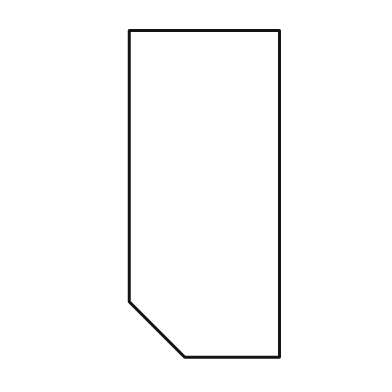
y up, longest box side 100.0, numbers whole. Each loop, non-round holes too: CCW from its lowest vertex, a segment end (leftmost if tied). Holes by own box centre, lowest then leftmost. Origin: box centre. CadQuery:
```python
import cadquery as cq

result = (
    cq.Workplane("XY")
    .moveTo(-6.0, -50.0)
    .lineTo(23.0, -50.0)
    .lineTo(23.0, 50.0)
    .lineTo(-23.0, 50.0)
    .lineTo(-23.0, -33.0)
    .close()
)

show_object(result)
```